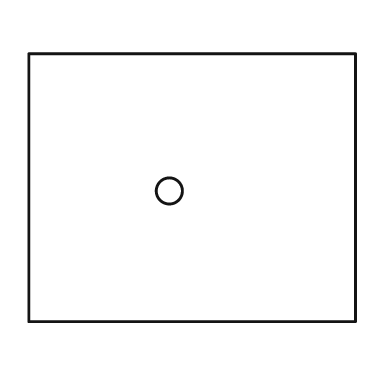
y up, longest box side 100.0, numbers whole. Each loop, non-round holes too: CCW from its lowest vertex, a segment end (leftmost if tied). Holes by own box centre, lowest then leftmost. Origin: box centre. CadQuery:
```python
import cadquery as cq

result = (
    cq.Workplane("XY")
    .moveTo(-50.0, -41.0)
    .lineTo(50.0, -41.0)
    .lineTo(50.0, 41.0)
    .lineTo(-50.0, 41.0)
    .close()
    .moveTo(-7.0, -1.0)
    .circle(4.0)
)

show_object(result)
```